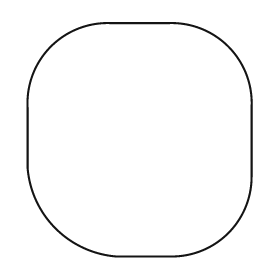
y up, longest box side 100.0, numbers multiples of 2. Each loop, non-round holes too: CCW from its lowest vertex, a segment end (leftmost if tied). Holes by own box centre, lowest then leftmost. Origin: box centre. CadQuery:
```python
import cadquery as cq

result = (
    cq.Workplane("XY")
    .moveTo(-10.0, -50.0)
    .lineTo(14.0, -50.0)
    .threePointArc((38.0, -40.0), (48.0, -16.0))
    .lineTo(48.0, 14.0)
    .threePointArc((38.0, 40.0), (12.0, 50.0))
    .lineTo(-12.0, 50.0)
    .threePointArc((-38.0, 40.0), (-48.0, 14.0))
    .lineTo(-48.0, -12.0)
    .threePointArc((-36.0, -38.0), (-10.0, -50.0))
    .close()
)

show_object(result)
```